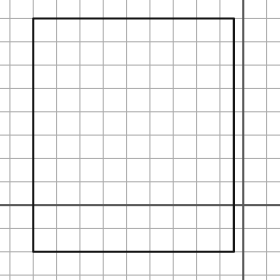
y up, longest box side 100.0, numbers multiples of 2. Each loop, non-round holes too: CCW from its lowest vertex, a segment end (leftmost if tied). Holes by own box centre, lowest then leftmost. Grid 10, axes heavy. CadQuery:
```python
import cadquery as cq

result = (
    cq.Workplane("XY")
    .moveTo(-90.0, -20.0)
    .lineTo(-4.0, -20.0)
    .lineTo(-4.0, 80.0)
    .lineTo(-90.0, 80.0)
    .close()
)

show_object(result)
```